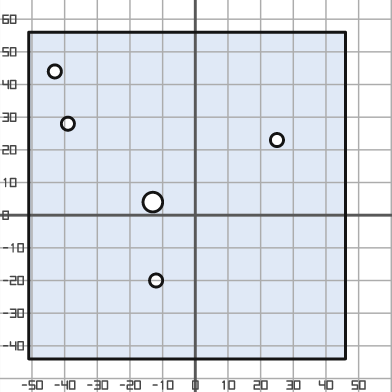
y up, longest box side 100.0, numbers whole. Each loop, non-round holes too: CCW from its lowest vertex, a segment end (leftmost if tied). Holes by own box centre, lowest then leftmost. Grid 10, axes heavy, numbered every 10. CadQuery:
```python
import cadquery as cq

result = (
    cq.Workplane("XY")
    .moveTo(-51.0, -44.0)
    .lineTo(46.0, -44.0)
    .lineTo(46.0, 56.0)
    .lineTo(-51.0, 56.0)
    .close()
    .moveTo(-12.0, -20.0)
    .circle(2.0)
    .moveTo(-13.0, 4.0)
    .circle(3.0)
    .moveTo(25.0, 23.0)
    .circle(2.0)
    .moveTo(-39.0, 28.0)
    .circle(2.0)
    .moveTo(-43.0, 44.0)
    .circle(2.0)
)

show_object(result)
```